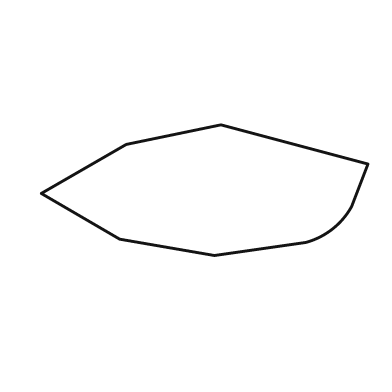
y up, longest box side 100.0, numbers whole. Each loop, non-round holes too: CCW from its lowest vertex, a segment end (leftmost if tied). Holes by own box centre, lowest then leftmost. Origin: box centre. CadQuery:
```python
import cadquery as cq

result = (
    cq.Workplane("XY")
    .moveTo(3.0, -20.0)
    .lineTo(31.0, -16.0)
    .threePointArc((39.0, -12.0), (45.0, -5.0))
    .lineTo(50.0, 8.0)
    .lineTo(5.0, 20.0)
    .lineTo(-24.0, 14.0)
    .lineTo(-50.0, -1.0)
    .lineTo(-26.0, -15.0)
    .close()
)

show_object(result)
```